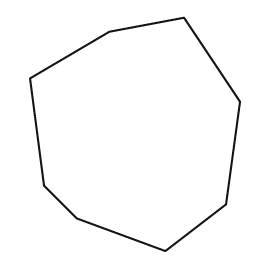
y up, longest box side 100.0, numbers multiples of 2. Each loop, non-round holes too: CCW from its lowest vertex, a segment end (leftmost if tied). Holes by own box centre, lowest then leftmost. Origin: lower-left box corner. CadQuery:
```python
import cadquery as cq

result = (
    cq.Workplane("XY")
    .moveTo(58.0, 0.0)
    .lineTo(84.0, 20.0)
    .lineTo(90.0, 64.0)
    .lineTo(66.0, 100.0)
    .lineTo(34.0, 94.0)
    .lineTo(0.0, 74.0)
    .lineTo(6.0, 28.0)
    .lineTo(20.0, 14.0)
    .close()
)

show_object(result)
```